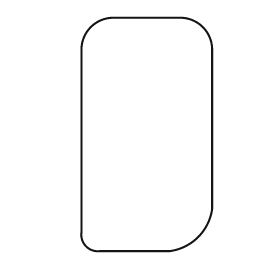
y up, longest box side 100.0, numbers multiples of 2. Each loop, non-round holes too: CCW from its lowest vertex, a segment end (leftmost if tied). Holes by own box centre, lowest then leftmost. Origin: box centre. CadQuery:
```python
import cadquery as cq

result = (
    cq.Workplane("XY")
    .moveTo(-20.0, -50.0)
    .lineTo(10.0, -50.0)
    .threePointArc((22.0, -44.0), (28.0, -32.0))
    .lineTo(28.0, 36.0)
    .threePointArc((24.0, 46.0), (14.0, 50.0))
    .lineTo(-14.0, 50.0)
    .threePointArc((-24.0, 46.0), (-28.0, 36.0))
    .lineTo(-28.0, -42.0)
    .threePointArc((-26.0, -48.0), (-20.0, -50.0))
    .close()
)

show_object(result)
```